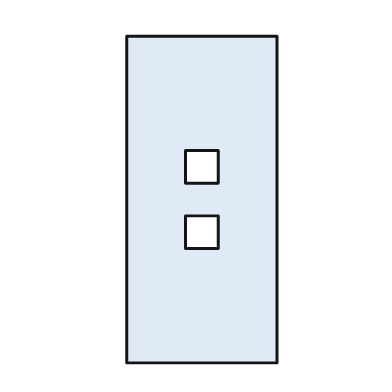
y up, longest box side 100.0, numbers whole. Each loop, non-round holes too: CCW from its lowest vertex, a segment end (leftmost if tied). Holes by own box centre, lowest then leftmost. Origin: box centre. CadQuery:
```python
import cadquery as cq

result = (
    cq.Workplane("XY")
    .moveTo(-23.0, -50.0)
    .lineTo(23.0, -50.0)
    .lineTo(23.0, 50.0)
    .lineTo(-23.0, 50.0)
    .close()
    .moveTo(-5.0, -15.0)
    .lineTo(5.0, -15.0)
    .lineTo(5.0, -5.0)
    .lineTo(-5.0, -5.0)
    .close()
    .moveTo(-5.0, 5.0)
    .lineTo(5.0, 5.0)
    .lineTo(5.0, 15.0)
    .lineTo(-5.0, 15.0)
    .close()
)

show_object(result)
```